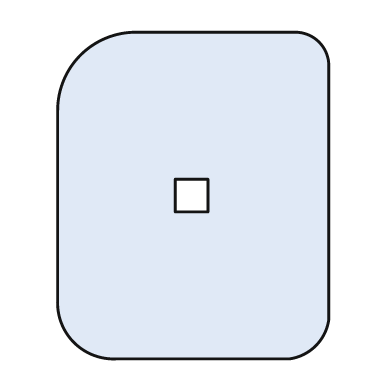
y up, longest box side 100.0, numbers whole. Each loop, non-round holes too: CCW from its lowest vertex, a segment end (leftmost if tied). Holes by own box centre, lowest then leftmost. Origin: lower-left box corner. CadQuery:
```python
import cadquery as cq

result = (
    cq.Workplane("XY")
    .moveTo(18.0, 0.0)
    .lineTo(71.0, 0.0)
    .threePointArc((79.0, 4.0), (83.0, 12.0))
    .lineTo(83.0, 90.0)
    .threePointArc((80.0, 97.0), (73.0, 100.0))
    .lineTo(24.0, 100.0)
    .threePointArc((7.0, 93.0), (0.0, 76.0))
    .lineTo(0.0, 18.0)
    .threePointArc((5.0, 5.0), (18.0, 0.0))
    .close()
    .moveTo(36.0, 45.0)
    .lineTo(46.0, 45.0)
    .lineTo(46.0, 55.0)
    .lineTo(36.0, 55.0)
    .close()
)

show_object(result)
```